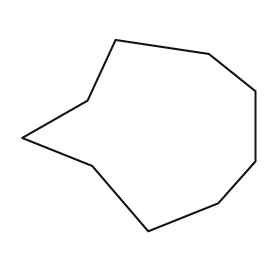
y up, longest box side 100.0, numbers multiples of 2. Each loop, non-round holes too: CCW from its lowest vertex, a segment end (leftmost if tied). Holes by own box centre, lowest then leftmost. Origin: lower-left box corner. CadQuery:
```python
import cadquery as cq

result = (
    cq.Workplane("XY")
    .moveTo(54.0, 0.0)
    .lineTo(84.0, 12.0)
    .lineTo(100.0, 30.0)
    .lineTo(100.0, 60.0)
    .lineTo(80.0, 76.0)
    .lineTo(40.0, 82.0)
    .lineTo(28.0, 56.0)
    .lineTo(0.0, 40.0)
    .lineTo(30.0, 28.0)
    .close()
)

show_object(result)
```